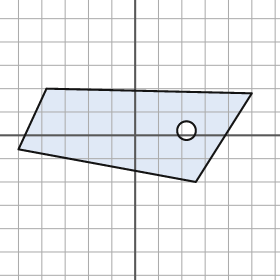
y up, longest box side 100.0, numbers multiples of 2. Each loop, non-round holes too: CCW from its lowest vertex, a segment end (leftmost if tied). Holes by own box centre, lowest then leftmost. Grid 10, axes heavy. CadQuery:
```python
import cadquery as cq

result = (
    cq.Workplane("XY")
    .moveTo(26.0, -20.0)
    .lineTo(50.0, 18.0)
    .lineTo(-38.0, 20.0)
    .lineTo(-50.0, -6.0)
    .close()
    .moveTo(22.0, 2.0)
    .circle(4.0)
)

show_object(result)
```